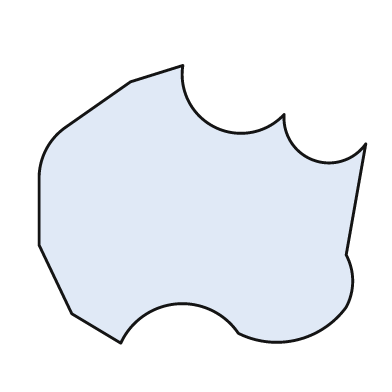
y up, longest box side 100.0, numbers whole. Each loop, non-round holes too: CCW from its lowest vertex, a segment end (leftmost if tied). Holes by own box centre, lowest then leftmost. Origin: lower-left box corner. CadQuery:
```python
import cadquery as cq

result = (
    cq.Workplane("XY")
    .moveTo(25.0, 0.0)
    .threePointArc((42.0, 12.0), (61.0, 3.0))
    .threePointArc((79.0, 1.0), (94.0, 11.0))
    .threePointArc((96.0, 19.0), (94.0, 27.0))
    .lineTo(100.0, 61.0)
    .threePointArc((84.0, 56.0), (75.0, 70.0))
    .threePointArc((54.0, 66.0), (44.0, 85.0))
    .lineTo(28.0, 80.0)
    .lineTo(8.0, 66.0)
    .threePointArc((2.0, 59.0), (0.0, 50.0))
    .lineTo(0.0, 30.0)
    .lineTo(10.0, 9.0)
    .close()
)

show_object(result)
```